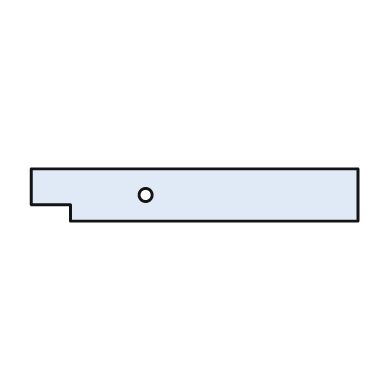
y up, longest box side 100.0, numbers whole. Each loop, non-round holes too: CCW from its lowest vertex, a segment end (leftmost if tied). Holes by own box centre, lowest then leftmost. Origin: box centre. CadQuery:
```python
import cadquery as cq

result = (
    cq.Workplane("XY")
    .moveTo(-38.0, -8.0)
    .lineTo(50.0, -8.0)
    .lineTo(50.0, 8.0)
    .lineTo(-50.0, 8.0)
    .lineTo(-50.0, -3.0)
    .lineTo(-38.0, -3.0)
    .close()
    .moveTo(-15.0, 0.0)
    .circle(2.0)
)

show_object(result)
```